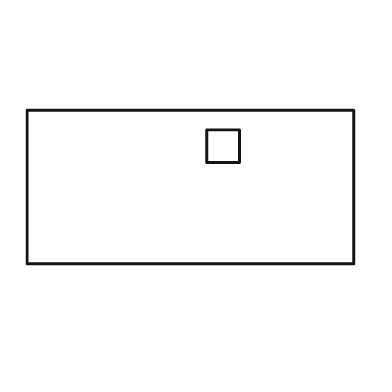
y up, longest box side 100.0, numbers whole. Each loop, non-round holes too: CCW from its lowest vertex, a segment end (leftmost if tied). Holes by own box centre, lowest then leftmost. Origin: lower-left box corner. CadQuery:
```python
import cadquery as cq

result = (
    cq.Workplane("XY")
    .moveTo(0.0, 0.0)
    .lineTo(100.0, 0.0)
    .lineTo(100.0, 47.0)
    .lineTo(0.0, 47.0)
    .close()
    .moveTo(55.0, 31.0)
    .lineTo(65.0, 31.0)
    .lineTo(65.0, 41.0)
    .lineTo(55.0, 41.0)
    .close()
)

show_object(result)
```